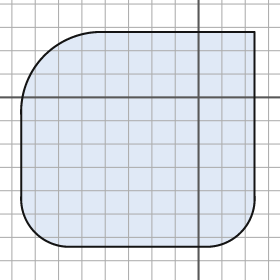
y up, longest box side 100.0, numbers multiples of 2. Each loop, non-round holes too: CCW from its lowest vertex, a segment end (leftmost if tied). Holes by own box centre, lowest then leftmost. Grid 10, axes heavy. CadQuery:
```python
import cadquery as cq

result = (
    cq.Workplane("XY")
    .moveTo(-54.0, -64.0)
    .lineTo(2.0, -64.0)
    .threePointArc((18.0, -58.0), (24.0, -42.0))
    .lineTo(24.0, 28.0)
    .lineTo(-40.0, 28.0)
    .threePointArc((-66.0, 18.0), (-76.0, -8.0))
    .lineTo(-76.0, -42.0)
    .threePointArc((-70.0, -58.0), (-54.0, -64.0))
    .close()
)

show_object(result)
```